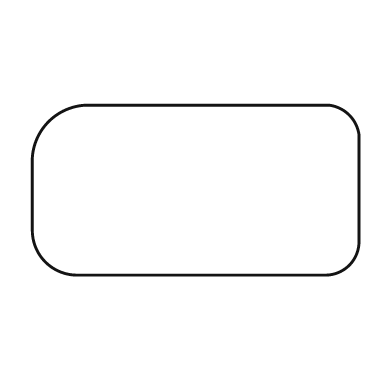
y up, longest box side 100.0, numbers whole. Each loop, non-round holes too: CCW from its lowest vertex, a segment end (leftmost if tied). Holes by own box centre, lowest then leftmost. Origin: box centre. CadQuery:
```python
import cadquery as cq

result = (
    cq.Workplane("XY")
    .moveTo(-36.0, -26.0)
    .lineTo(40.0, -26.0)
    .threePointArc((47.0, -23.0), (50.0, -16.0))
    .lineTo(50.0, 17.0)
    .threePointArc((47.0, 23.0), (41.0, 26.0))
    .lineTo(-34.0, 26.0)
    .threePointArc((-45.0, 21.0), (-50.0, 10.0))
    .lineTo(-50.0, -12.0)
    .threePointArc((-46.0, -22.0), (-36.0, -26.0))
    .close()
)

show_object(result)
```